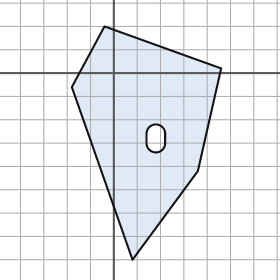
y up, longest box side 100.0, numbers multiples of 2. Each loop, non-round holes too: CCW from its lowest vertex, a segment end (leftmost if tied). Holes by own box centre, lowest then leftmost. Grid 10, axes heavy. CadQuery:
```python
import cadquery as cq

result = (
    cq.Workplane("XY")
    .moveTo(8.0, -80.0)
    .lineTo(36.0, -42.0)
    .lineTo(46.0, 2.0)
    .lineTo(-4.0, 20.0)
    .lineTo(-18.0, -6.0)
    .close()
    .moveTo(14.0, -30.0)
    .threePointArc((18.0, -34.0), (22.0, -30.0))
    .lineTo(22.0, -26.0)
    .threePointArc((18.0, -22.0), (14.0, -26.0))
    .close()
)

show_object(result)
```